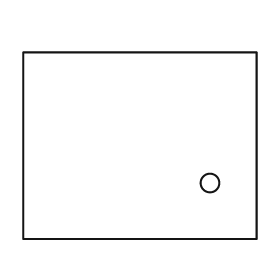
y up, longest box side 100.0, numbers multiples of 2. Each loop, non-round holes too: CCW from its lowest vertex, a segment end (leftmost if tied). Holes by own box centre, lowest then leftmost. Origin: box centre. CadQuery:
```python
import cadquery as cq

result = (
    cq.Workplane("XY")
    .moveTo(-50.0, -40.0)
    .lineTo(50.0, -40.0)
    .lineTo(50.0, 40.0)
    .lineTo(-50.0, 40.0)
    .close()
    .moveTo(30.0, -16.0)
    .circle(4.0)
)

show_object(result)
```